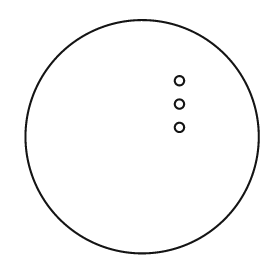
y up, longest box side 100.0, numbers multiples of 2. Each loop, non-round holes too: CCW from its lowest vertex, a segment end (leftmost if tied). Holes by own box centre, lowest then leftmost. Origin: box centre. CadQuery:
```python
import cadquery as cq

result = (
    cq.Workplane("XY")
    .moveTo(0.0, 0.0)
    .circle(50.0)
    .moveTo(16.0, 4.0)
    .circle(2.0)
    .moveTo(16.0, 14.0)
    .circle(2.0)
    .moveTo(16.0, 24.0)
    .circle(2.0)
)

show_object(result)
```